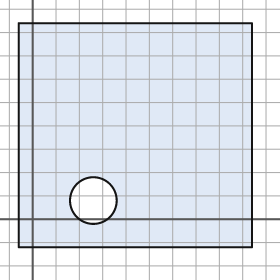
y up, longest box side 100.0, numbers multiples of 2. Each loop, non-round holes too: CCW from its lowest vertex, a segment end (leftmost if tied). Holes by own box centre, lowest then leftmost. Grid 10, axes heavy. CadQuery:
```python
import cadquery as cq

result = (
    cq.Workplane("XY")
    .moveTo(-6.0, -12.0)
    .lineTo(94.0, -12.0)
    .lineTo(94.0, 84.0)
    .lineTo(-6.0, 84.0)
    .close()
    .moveTo(26.0, 8.0)
    .circle(10.0)
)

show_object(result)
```